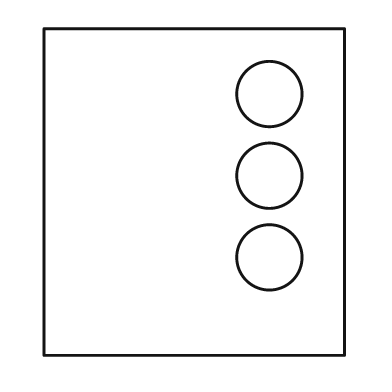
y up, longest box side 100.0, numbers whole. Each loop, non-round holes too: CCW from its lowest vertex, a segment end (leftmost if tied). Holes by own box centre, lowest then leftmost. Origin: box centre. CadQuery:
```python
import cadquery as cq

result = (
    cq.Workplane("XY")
    .moveTo(-46.0, -50.0)
    .lineTo(46.0, -50.0)
    .lineTo(46.0, 50.0)
    .lineTo(-46.0, 50.0)
    .close()
    .moveTo(23.0, -20.0)
    .circle(10.0)
    .moveTo(23.0, 5.0)
    .circle(10.0)
    .moveTo(23.0, 30.0)
    .circle(10.0)
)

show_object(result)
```